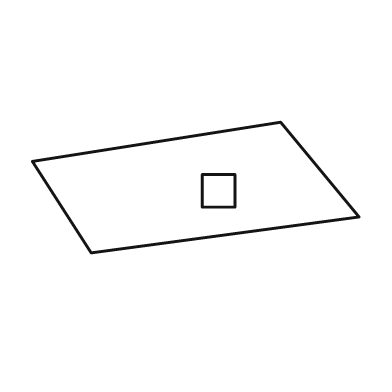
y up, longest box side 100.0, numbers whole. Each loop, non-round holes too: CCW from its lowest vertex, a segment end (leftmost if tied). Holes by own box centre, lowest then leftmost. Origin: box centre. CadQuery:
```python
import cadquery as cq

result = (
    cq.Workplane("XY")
    .moveTo(-32.0, -20.0)
    .lineTo(50.0, -9.0)
    .lineTo(26.0, 20.0)
    .lineTo(-50.0, 8.0)
    .close()
    .moveTo(2.0, -6.0)
    .lineTo(12.0, -6.0)
    .lineTo(12.0, 4.0)
    .lineTo(2.0, 4.0)
    .close()
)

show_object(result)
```